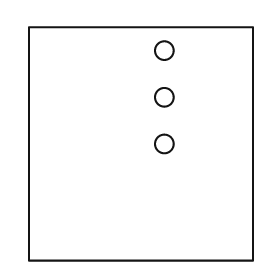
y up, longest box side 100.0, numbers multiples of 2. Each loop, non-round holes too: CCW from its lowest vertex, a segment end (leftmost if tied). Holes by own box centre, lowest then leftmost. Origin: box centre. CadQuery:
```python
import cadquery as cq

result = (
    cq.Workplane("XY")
    .moveTo(-48.0, -50.0)
    .lineTo(48.0, -50.0)
    .lineTo(48.0, 50.0)
    .lineTo(-48.0, 50.0)
    .close()
    .moveTo(10.0, 0.0)
    .circle(4.0)
    .moveTo(10.0, 20.0)
    .circle(4.0)
    .moveTo(10.0, 40.0)
    .circle(4.0)
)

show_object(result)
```